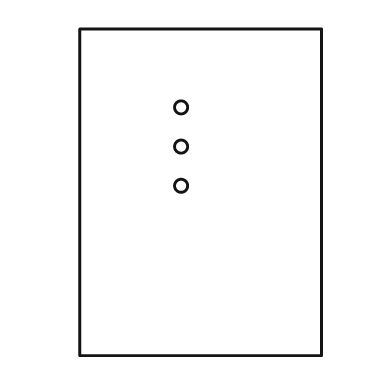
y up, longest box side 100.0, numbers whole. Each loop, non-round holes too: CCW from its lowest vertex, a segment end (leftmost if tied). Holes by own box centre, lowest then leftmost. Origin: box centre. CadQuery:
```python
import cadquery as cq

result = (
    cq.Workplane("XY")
    .moveTo(-37.0, -50.0)
    .lineTo(37.0, -50.0)
    .lineTo(37.0, 50.0)
    .lineTo(-37.0, 50.0)
    .close()
    .moveTo(-6.0, 2.0)
    .circle(2.0)
    .moveTo(-6.0, 14.0)
    .circle(2.0)
    .moveTo(-6.0, 26.0)
    .circle(2.0)
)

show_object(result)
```